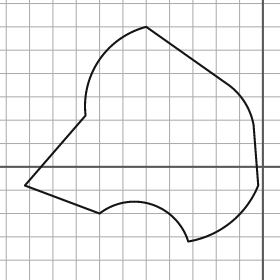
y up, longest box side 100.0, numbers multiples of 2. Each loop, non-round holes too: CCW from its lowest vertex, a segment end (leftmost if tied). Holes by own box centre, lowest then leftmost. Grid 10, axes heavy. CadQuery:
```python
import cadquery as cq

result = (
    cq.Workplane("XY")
    .moveTo(-32.0, -32.0)
    .threePointArc((-14.0, -24.0), (-2.0, -8.0))
    .lineTo(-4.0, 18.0)
    .threePointArc((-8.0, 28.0), (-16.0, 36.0))
    .lineTo(-50.0, 60.0)
    .threePointArc((-70.0, 46.0), (-76.0, 22.0))
    .lineTo(-102.0, -8.0)
    .lineTo(-70.0, -20.0)
    .threePointArc((-48.0, -16.0), (-32.0, -32.0))
    .close()
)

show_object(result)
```